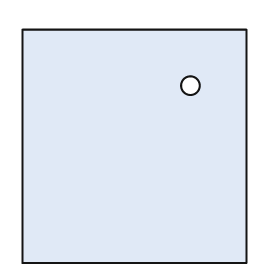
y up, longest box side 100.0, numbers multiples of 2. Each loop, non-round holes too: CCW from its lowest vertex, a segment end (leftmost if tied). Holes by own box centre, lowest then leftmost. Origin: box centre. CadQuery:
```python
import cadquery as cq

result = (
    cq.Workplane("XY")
    .moveTo(-48.0, -50.0)
    .lineTo(48.0, -50.0)
    .lineTo(48.0, 50.0)
    .lineTo(-48.0, 50.0)
    .close()
    .moveTo(24.0, 26.0)
    .circle(4.0)
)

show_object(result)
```